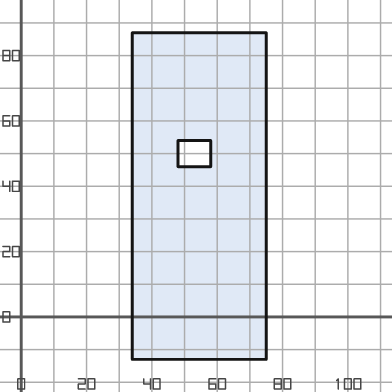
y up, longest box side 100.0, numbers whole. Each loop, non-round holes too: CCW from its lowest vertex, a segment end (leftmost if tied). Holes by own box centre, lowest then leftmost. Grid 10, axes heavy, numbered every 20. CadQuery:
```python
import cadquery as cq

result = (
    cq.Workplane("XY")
    .moveTo(34.0, -13.0)
    .lineTo(75.0, -13.0)
    .lineTo(75.0, 87.0)
    .lineTo(34.0, 87.0)
    .close()
    .moveTo(48.0, 46.0)
    .lineTo(58.0, 46.0)
    .lineTo(58.0, 54.0)
    .lineTo(48.0, 54.0)
    .close()
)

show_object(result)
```